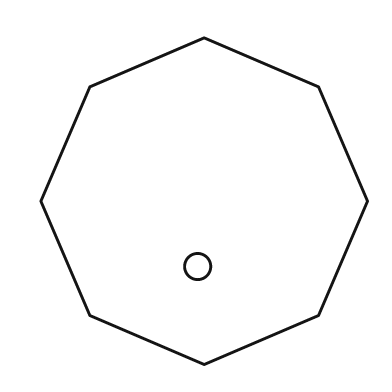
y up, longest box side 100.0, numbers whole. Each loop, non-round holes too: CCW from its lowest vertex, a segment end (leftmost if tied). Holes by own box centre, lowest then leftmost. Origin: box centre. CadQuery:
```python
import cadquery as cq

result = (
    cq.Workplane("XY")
    .moveTo(0.0, -50.0)
    .lineTo(35.0, -35.0)
    .lineTo(50.0, 0.0)
    .lineTo(35.0, 35.0)
    .lineTo(0.0, 50.0)
    .lineTo(-35.0, 35.0)
    .lineTo(-50.0, 0.0)
    .lineTo(-35.0, -35.0)
    .close()
    .moveTo(-2.0, -20.0)
    .circle(4.0)
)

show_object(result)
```